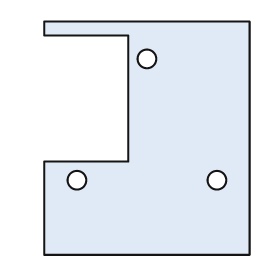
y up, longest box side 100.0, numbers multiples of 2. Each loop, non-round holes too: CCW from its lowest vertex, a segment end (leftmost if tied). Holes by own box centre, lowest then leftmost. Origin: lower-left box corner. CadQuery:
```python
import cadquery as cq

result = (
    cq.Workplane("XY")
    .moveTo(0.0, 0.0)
    .lineTo(88.0, 0.0)
    .lineTo(88.0, 100.0)
    .lineTo(0.0, 100.0)
    .lineTo(0.0, 94.0)
    .lineTo(36.0, 94.0)
    .lineTo(36.0, 40.0)
    .lineTo(0.0, 40.0)
    .close()
    .moveTo(14.0, 32.0)
    .circle(4.0)
    .moveTo(74.0, 32.0)
    .circle(4.0)
    .moveTo(44.0, 84.0)
    .circle(4.0)
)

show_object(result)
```